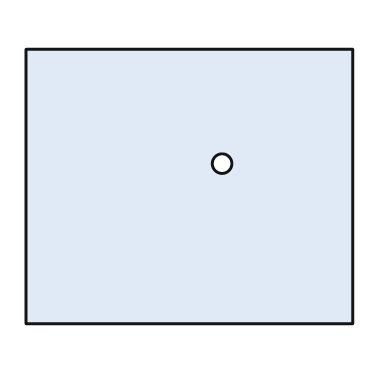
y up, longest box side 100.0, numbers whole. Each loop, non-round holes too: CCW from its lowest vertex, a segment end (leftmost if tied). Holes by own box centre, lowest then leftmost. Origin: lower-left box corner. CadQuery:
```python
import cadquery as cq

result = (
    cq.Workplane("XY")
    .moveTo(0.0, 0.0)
    .lineTo(100.0, 0.0)
    .lineTo(100.0, 84.0)
    .lineTo(0.0, 84.0)
    .close()
    .moveTo(60.0, 49.0)
    .circle(3.0)
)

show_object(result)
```